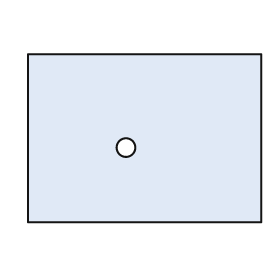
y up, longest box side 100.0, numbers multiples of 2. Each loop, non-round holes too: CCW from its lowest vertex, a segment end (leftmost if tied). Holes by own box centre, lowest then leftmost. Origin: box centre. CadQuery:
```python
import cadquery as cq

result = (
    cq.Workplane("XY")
    .moveTo(-50.0, -36.0)
    .lineTo(50.0, -36.0)
    .lineTo(50.0, 36.0)
    .lineTo(-50.0, 36.0)
    .close()
    .moveTo(-8.0, -4.0)
    .circle(4.0)
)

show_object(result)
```